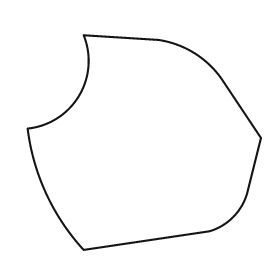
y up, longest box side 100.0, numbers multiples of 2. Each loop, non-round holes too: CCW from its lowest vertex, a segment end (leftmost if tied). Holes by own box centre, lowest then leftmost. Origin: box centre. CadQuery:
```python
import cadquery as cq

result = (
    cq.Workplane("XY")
    .moveTo(-26.0, -46.0)
    .lineTo(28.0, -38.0)
    .threePointArc((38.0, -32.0), (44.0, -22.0))
    .lineTo(50.0, 2.0)
    .lineTo(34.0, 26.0)
    .threePointArc((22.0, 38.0), (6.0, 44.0))
    .lineTo(-26.0, 46.0)
    .threePointArc((-28.0, 20.0), (-50.0, 6.0))
    .threePointArc((-42.0, -22.0), (-26.0, -46.0))
    .close()
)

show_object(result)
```